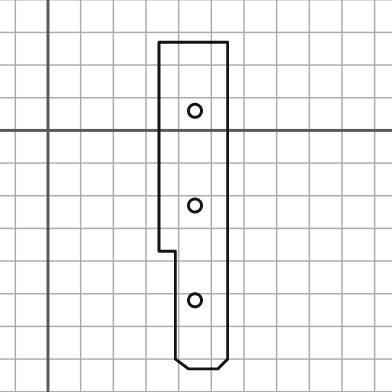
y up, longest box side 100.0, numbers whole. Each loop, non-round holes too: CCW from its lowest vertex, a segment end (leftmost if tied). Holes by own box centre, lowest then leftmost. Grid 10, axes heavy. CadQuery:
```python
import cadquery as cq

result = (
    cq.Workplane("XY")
    .moveTo(43.0, -73.0)
    .lineTo(52.0, -73.0)
    .lineTo(55.0, -70.0)
    .lineTo(55.0, 27.0)
    .lineTo(34.0, 27.0)
    .lineTo(34.0, -37.0)
    .lineTo(39.0, -37.0)
    .lineTo(39.0, -70.0)
    .close()
    .moveTo(45.0, -52.0)
    .circle(2.0)
    .moveTo(45.0, -23.0)
    .circle(2.0)
    .moveTo(45.0, 6.0)
    .circle(2.0)
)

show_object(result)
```